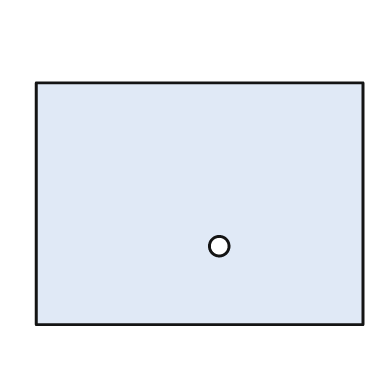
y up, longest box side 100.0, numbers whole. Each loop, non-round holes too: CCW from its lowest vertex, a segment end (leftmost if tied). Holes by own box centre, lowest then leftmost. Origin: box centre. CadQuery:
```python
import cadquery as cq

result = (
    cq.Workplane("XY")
    .moveTo(-50.0, -37.0)
    .lineTo(50.0, -37.0)
    .lineTo(50.0, 37.0)
    .lineTo(-50.0, 37.0)
    .close()
    .moveTo(6.0, -13.0)
    .circle(3.0)
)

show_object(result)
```